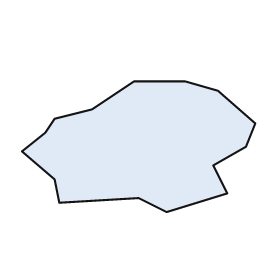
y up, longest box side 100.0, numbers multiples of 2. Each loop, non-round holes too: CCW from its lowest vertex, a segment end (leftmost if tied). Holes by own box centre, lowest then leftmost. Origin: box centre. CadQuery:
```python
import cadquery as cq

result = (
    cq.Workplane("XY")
    .moveTo(12.0, -28.0)
    .lineTo(38.0, -20.0)
    .lineTo(32.0, -8.0)
    .lineTo(46.0, 0.0)
    .lineTo(50.0, 10.0)
    .lineTo(34.0, 24.0)
    .lineTo(20.0, 28.0)
    .lineTo(-2.0, 28.0)
    .lineTo(-20.0, 16.0)
    .lineTo(-36.0, 12.0)
    .lineTo(-40.0, 6.0)
    .lineTo(-50.0, -2.0)
    .lineTo(-36.0, -14.0)
    .lineTo(-34.0, -24.0)
    .lineTo(0.0, -22.0)
    .close()
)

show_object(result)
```